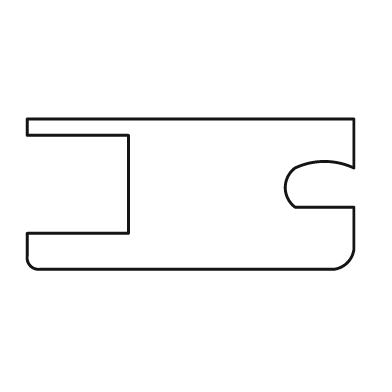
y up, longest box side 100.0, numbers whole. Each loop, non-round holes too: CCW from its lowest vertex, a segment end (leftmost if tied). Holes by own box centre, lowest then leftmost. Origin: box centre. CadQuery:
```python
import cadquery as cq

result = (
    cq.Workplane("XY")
    .moveTo(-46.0, -23.0)
    .lineTo(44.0, -23.0)
    .threePointArc((48.0, -21.0), (50.0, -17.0))
    .lineTo(50.0, -4.0)
    .lineTo(32.0, -4.0)
    .threePointArc((29.0, 2.0), (32.0, 8.0))
    .threePointArc((41.0, 10.0), (50.0, 8.0))
    .lineTo(50.0, 23.0)
    .lineTo(-50.0, 23.0)
    .lineTo(-50.0, 18.0)
    .lineTo(-19.0, 18.0)
    .lineTo(-19.0, -12.0)
    .lineTo(-50.0, -12.0)
    .lineTo(-50.0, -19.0)
    .threePointArc((-49.0, -22.0), (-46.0, -23.0))
    .close()
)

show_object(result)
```